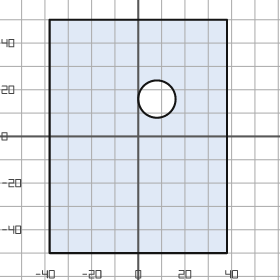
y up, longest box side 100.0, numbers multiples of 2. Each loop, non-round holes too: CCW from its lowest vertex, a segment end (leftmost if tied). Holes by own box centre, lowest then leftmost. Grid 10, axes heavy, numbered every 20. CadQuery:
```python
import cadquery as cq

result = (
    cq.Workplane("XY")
    .moveTo(-38.0, -50.0)
    .lineTo(38.0, -50.0)
    .lineTo(38.0, 50.0)
    .lineTo(-38.0, 50.0)
    .close()
    .moveTo(8.0, 16.0)
    .circle(8.0)
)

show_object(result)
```